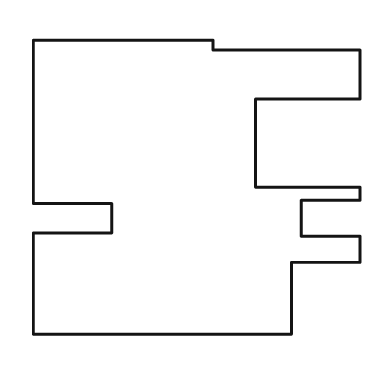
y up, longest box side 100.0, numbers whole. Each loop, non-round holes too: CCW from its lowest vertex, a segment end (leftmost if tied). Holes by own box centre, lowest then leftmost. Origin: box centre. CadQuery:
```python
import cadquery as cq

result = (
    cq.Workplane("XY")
    .moveTo(-50.0, -45.0)
    .lineTo(29.0, -45.0)
    .lineTo(29.0, -23.0)
    .lineTo(50.0, -23.0)
    .lineTo(50.0, -15.0)
    .lineTo(32.0, -15.0)
    .lineTo(32.0, -4.0)
    .lineTo(50.0, -4.0)
    .lineTo(50.0, 0.0)
    .lineTo(18.0, 0.0)
    .lineTo(18.0, 27.0)
    .lineTo(50.0, 27.0)
    .lineTo(50.0, 42.0)
    .lineTo(5.0, 42.0)
    .lineTo(5.0, 45.0)
    .lineTo(-50.0, 45.0)
    .lineTo(-50.0, -5.0)
    .lineTo(-26.0, -5.0)
    .lineTo(-26.0, -14.0)
    .lineTo(-50.0, -14.0)
    .close()
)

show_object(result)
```